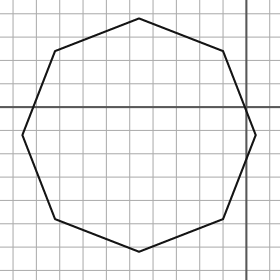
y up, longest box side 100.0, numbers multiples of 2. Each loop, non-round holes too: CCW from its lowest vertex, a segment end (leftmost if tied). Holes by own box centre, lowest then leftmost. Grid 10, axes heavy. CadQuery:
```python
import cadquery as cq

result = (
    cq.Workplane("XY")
    .moveTo(-46.0, -62.0)
    .lineTo(-10.0, -48.0)
    .lineTo(4.0, -12.0)
    .lineTo(-10.0, 24.0)
    .lineTo(-46.0, 38.0)
    .lineTo(-82.0, 24.0)
    .lineTo(-96.0, -12.0)
    .lineTo(-82.0, -48.0)
    .close()
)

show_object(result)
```